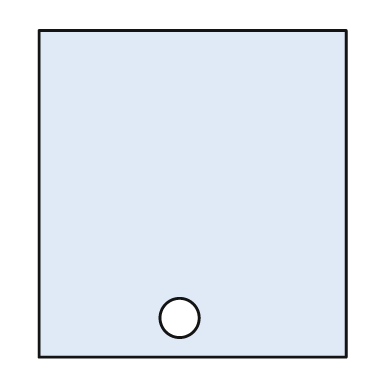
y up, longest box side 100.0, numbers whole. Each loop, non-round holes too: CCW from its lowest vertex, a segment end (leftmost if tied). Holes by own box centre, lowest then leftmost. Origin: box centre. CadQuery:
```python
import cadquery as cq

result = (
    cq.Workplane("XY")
    .moveTo(-47.0, -50.0)
    .lineTo(47.0, -50.0)
    .lineTo(47.0, 50.0)
    .lineTo(-47.0, 50.0)
    .close()
    .moveTo(-4.0, -38.0)
    .circle(6.0)
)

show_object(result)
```